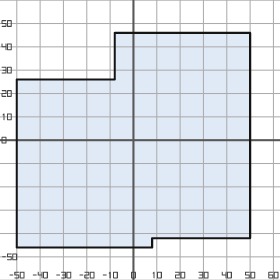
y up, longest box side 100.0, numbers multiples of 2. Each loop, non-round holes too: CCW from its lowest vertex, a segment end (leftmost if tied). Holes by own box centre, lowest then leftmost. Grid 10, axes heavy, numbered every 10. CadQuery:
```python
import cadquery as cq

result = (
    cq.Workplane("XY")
    .moveTo(-50.0, -46.0)
    .lineTo(8.0, -46.0)
    .lineTo(8.0, -42.0)
    .lineTo(50.0, -42.0)
    .lineTo(50.0, 46.0)
    .lineTo(-8.0, 46.0)
    .lineTo(-8.0, 26.0)
    .lineTo(-50.0, 26.0)
    .close()
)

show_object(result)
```